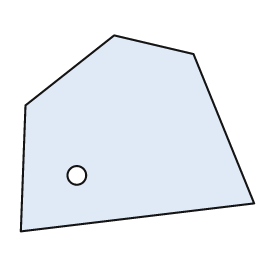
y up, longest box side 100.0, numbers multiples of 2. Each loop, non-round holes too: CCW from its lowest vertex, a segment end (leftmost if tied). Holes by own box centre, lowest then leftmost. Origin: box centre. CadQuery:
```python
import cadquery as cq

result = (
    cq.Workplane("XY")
    .moveTo(-50.0, -42.0)
    .lineTo(50.0, -30.0)
    .lineTo(24.0, 34.0)
    .lineTo(-10.0, 42.0)
    .lineTo(-48.0, 12.0)
    .close()
    .moveTo(-26.0, -18.0)
    .circle(4.0)
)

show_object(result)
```